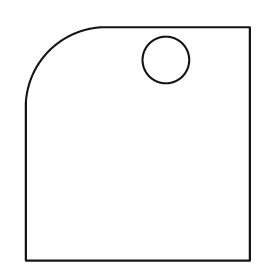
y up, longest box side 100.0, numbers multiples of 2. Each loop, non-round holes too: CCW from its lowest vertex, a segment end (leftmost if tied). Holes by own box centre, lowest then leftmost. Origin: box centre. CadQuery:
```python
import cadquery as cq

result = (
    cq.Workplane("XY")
    .moveTo(-48.0, -50.0)
    .lineTo(48.0, -50.0)
    .lineTo(48.0, 50.0)
    .lineTo(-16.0, 50.0)
    .threePointArc((-38.0, 40.0), (-48.0, 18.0))
    .close()
    .moveTo(12.0, 36.0)
    .circle(10.0)
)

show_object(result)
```